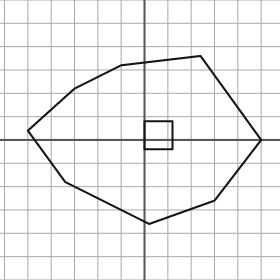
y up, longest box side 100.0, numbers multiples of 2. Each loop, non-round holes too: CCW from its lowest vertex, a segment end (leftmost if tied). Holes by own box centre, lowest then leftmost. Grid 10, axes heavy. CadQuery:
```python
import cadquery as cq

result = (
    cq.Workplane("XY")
    .moveTo(2.0, -36.0)
    .lineTo(30.0, -26.0)
    .lineTo(50.0, 0.0)
    .lineTo(24.0, 36.0)
    .lineTo(-10.0, 32.0)
    .lineTo(-30.0, 22.0)
    .lineTo(-50.0, 4.0)
    .lineTo(-34.0, -18.0)
    .close()
    .moveTo(0.0, -4.0)
    .lineTo(12.0, -4.0)
    .lineTo(12.0, 8.0)
    .lineTo(0.0, 8.0)
    .close()
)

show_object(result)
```